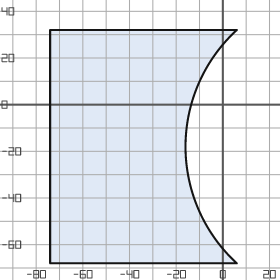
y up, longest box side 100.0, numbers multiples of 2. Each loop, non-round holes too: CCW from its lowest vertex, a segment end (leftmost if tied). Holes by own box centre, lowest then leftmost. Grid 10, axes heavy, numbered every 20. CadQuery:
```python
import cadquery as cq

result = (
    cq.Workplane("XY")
    .moveTo(-74.0, -68.0)
    .lineTo(6.0, -68.0)
    .threePointArc((-16.0, -18.0), (6.0, 32.0))
    .lineTo(-74.0, 32.0)
    .close()
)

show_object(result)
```